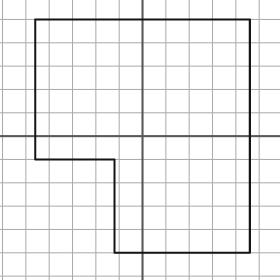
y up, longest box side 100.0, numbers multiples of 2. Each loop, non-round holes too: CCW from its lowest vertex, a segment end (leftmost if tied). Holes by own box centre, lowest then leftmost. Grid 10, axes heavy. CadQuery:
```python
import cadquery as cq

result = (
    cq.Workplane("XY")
    .moveTo(-12.0, -50.0)
    .lineTo(46.0, -50.0)
    .lineTo(46.0, 50.0)
    .lineTo(-46.0, 50.0)
    .lineTo(-46.0, -10.0)
    .lineTo(-12.0, -10.0)
    .close()
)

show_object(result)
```